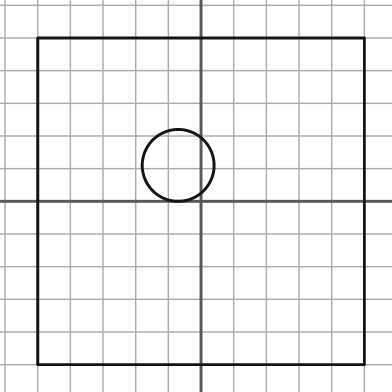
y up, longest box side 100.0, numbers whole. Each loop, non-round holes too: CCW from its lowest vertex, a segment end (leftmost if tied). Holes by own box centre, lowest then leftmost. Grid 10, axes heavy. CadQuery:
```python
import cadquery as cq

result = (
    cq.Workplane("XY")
    .moveTo(-50.0, -50.0)
    .lineTo(50.0, -50.0)
    .lineTo(50.0, 50.0)
    .lineTo(-50.0, 50.0)
    .close()
    .moveTo(-7.0, 11.0)
    .circle(11.0)
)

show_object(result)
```